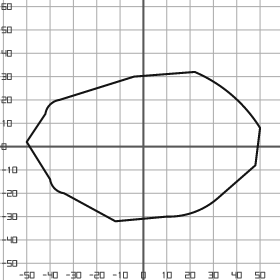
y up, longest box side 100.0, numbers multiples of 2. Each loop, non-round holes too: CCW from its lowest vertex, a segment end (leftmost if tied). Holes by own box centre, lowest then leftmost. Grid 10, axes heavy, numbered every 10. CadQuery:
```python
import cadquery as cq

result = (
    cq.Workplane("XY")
    .moveTo(-12.0, -32.0)
    .lineTo(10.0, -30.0)
    .threePointArc((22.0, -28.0), (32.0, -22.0))
    .lineTo(48.0, -8.0)
    .lineTo(50.0, 8.0)
    .threePointArc((38.0, 22.0), (22.0, 32.0))
    .lineTo(-4.0, 30.0)
    .lineTo(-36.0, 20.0)
    .threePointArc((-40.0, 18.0), (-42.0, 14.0))
    .lineTo(-50.0, 2.0)
    .lineTo(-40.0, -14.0)
    .threePointArc((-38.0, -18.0), (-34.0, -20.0))
    .close()
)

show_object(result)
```